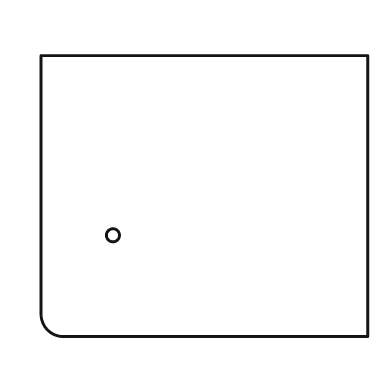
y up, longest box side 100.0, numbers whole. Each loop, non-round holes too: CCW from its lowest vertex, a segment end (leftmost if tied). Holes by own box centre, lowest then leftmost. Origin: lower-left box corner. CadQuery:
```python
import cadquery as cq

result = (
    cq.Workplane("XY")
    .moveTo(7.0, 0.0)
    .lineTo(100.0, 0.0)
    .lineTo(100.0, 86.0)
    .lineTo(0.0, 86.0)
    .lineTo(0.0, 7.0)
    .threePointArc((2.0, 2.0), (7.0, 0.0))
    .close()
    .moveTo(22.0, 31.0)
    .circle(2.0)
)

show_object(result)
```